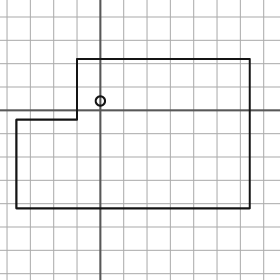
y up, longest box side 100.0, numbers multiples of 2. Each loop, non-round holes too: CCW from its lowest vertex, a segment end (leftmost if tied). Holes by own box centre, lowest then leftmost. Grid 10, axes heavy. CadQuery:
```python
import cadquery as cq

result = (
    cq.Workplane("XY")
    .moveTo(-36.0, -42.0)
    .lineTo(64.0, -42.0)
    .lineTo(64.0, 22.0)
    .lineTo(-10.0, 22.0)
    .lineTo(-10.0, -4.0)
    .lineTo(-36.0, -4.0)
    .close()
    .moveTo(0.0, 4.0)
    .circle(2.0)
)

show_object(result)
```